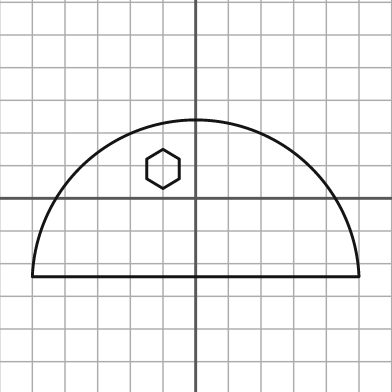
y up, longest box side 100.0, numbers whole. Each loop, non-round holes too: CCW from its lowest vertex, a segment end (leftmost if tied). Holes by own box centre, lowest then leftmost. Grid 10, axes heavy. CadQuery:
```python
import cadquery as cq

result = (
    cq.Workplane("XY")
    .moveTo(-50.0, -24.0)
    .lineTo(50.0, -24.0)
    .threePointArc((0.0, 24.0), (-50.0, -24.0))
    .close()
    .moveTo(-10.0, 3.0)
    .lineTo(-5.0, 6.0)
    .lineTo(-5.0, 12.0)
    .lineTo(-10.0, 15.0)
    .lineTo(-15.0, 12.0)
    .lineTo(-15.0, 6.0)
    .close()
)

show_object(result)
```